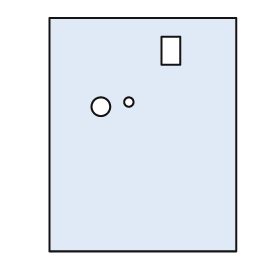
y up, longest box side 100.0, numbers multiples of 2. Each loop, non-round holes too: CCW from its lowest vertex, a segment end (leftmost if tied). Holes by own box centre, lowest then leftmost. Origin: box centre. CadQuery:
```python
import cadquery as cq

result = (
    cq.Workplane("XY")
    .moveTo(-40.0, -50.0)
    .lineTo(40.0, -50.0)
    .lineTo(40.0, 50.0)
    .lineTo(-40.0, 50.0)
    .close()
    .moveTo(-18.0, 12.0)
    .circle(4.0)
    .moveTo(-6.0, 14.0)
    .circle(2.0)
    .moveTo(8.0, 30.0)
    .lineTo(16.0, 30.0)
    .lineTo(16.0, 42.0)
    .lineTo(8.0, 42.0)
    .close()
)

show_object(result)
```